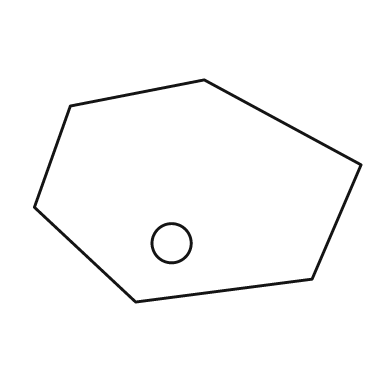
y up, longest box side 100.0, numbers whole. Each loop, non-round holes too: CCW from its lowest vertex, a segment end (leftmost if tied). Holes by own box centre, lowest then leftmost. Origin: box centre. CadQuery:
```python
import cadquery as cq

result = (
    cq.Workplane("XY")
    .moveTo(-19.0, -34.0)
    .lineTo(35.0, -27.0)
    .lineTo(50.0, 8.0)
    .lineTo(2.0, 34.0)
    .lineTo(-39.0, 26.0)
    .lineTo(-50.0, -5.0)
    .close()
    .moveTo(-8.0, -16.0)
    .circle(6.0)
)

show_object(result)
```